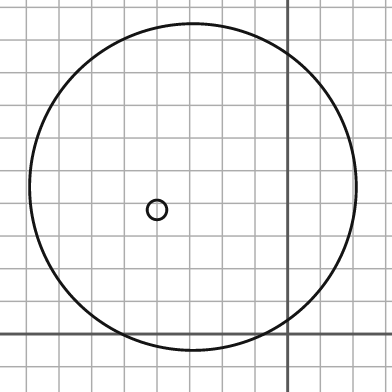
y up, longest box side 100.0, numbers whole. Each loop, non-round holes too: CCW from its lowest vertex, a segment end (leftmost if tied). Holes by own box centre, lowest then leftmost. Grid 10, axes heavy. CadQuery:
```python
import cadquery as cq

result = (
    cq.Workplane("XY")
    .moveTo(-29.0, 45.0)
    .circle(50.0)
    .moveTo(-40.0, 38.0)
    .circle(3.0)
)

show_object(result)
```